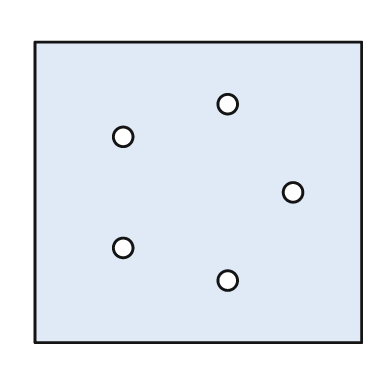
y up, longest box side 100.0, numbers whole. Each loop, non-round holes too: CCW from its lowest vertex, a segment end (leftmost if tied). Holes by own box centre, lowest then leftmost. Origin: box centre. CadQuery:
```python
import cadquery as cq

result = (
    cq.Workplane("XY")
    .moveTo(-50.0, -46.0)
    .lineTo(50.0, -46.0)
    .lineTo(50.0, 46.0)
    .lineTo(-50.0, 46.0)
    .close()
    .moveTo(9.0, -27.0)
    .circle(3.0)
    .moveTo(-23.0, -17.0)
    .circle(3.0)
    .moveTo(29.0, 0.0)
    .circle(3.0)
    .moveTo(-23.0, 17.0)
    .circle(3.0)
    .moveTo(9.0, 27.0)
    .circle(3.0)
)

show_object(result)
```